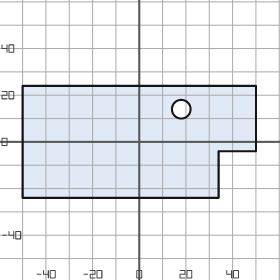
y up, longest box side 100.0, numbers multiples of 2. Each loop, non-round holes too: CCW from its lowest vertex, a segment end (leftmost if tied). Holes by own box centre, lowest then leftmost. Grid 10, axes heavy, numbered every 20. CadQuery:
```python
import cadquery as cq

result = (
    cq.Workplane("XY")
    .moveTo(-50.0, -24.0)
    .lineTo(34.0, -24.0)
    .lineTo(34.0, -4.0)
    .lineTo(50.0, -4.0)
    .lineTo(50.0, 24.0)
    .lineTo(-50.0, 24.0)
    .close()
    .moveTo(18.0, 14.0)
    .circle(4.0)
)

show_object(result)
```